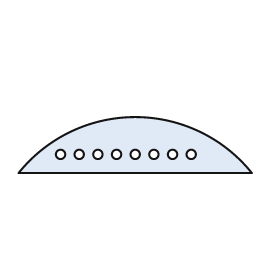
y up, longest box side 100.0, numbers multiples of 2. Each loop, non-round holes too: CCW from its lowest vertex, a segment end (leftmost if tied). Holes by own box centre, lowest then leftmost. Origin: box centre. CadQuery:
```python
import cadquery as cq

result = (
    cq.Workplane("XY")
    .moveTo(-50.0, -12.0)
    .lineTo(50.0, -12.0)
    .threePointArc((0.0, 12.0), (-50.0, -12.0))
    .close()
    .moveTo(-32.0, -4.0)
    .circle(2.0)
    .moveTo(-24.0, -4.0)
    .circle(2.0)
    .moveTo(-16.0, -4.0)
    .circle(2.0)
    .moveTo(-8.0, -4.0)
    .circle(2.0)
    .moveTo(0.0, -4.0)
    .circle(2.0)
    .moveTo(8.0, -4.0)
    .circle(2.0)
    .moveTo(16.0, -4.0)
    .circle(2.0)
    .moveTo(24.0, -4.0)
    .circle(2.0)
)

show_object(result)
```